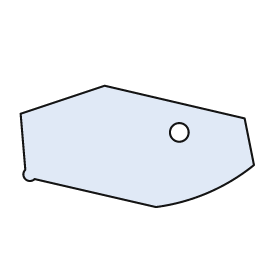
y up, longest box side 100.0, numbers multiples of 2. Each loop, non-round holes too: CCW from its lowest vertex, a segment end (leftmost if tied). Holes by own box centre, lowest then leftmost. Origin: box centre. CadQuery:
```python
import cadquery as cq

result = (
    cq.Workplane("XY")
    .moveTo(8.0, -26.0)
    .threePointArc((30.0, -20.0), (50.0, -8.0))
    .lineTo(46.0, 12.0)
    .lineTo(-14.0, 26.0)
    .lineTo(-50.0, 14.0)
    .lineTo(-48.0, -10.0)
    .threePointArc((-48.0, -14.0), (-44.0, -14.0))
    .close()
    .moveTo(18.0, 6.0)
    .circle(4.0)
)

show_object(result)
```